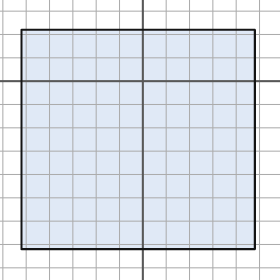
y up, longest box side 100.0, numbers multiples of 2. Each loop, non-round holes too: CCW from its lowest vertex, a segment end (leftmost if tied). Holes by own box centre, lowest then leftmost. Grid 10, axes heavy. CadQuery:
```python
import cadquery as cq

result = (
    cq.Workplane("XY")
    .moveTo(-52.0, -72.0)
    .lineTo(48.0, -72.0)
    .lineTo(48.0, 22.0)
    .lineTo(-52.0, 22.0)
    .close()
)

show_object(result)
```